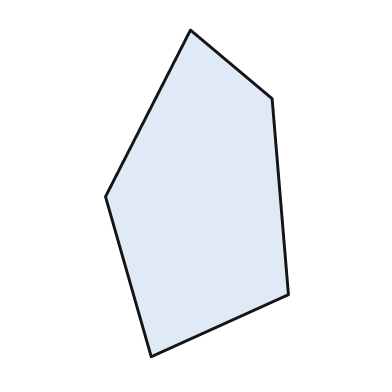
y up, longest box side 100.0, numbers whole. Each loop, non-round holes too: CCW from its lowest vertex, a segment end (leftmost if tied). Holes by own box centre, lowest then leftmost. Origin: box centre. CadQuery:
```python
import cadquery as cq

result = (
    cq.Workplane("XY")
    .moveTo(-14.0, -50.0)
    .lineTo(28.0, -31.0)
    .lineTo(23.0, 29.0)
    .lineTo(-2.0, 50.0)
    .lineTo(-28.0, -1.0)
    .close()
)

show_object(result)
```